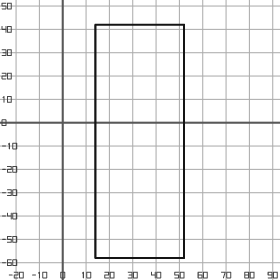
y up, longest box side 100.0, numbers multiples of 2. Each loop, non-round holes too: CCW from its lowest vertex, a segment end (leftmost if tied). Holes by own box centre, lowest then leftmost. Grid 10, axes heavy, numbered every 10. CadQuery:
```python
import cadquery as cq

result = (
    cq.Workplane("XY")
    .moveTo(14.0, -58.0)
    .lineTo(52.0, -58.0)
    .lineTo(52.0, 42.0)
    .lineTo(14.0, 42.0)
    .close()
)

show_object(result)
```